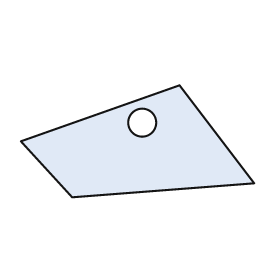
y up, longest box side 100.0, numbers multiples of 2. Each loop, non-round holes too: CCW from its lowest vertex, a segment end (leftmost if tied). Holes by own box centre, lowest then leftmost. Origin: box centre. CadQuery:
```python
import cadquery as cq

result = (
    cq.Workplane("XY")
    .moveTo(-28.0, -24.0)
    .lineTo(50.0, -18.0)
    .lineTo(18.0, 24.0)
    .lineTo(-50.0, 0.0)
    .close()
    .moveTo(2.0, 8.0)
    .circle(6.0)
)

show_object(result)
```